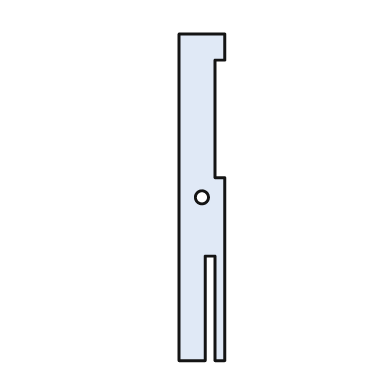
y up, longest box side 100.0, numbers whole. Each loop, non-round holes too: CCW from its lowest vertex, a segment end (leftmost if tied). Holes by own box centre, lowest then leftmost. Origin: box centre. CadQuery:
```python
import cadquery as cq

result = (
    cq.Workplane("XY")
    .moveTo(-7.0, -50.0)
    .lineTo(1.0, -50.0)
    .lineTo(1.0, -18.0)
    .lineTo(4.0, -18.0)
    .lineTo(4.0, -50.0)
    .lineTo(7.0, -50.0)
    .lineTo(7.0, 6.0)
    .lineTo(4.0, 6.0)
    .lineTo(4.0, 42.0)
    .lineTo(7.0, 42.0)
    .lineTo(7.0, 50.0)
    .lineTo(-7.0, 50.0)
    .close()
    .moveTo(0.0, 0.0)
    .circle(2.0)
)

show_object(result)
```